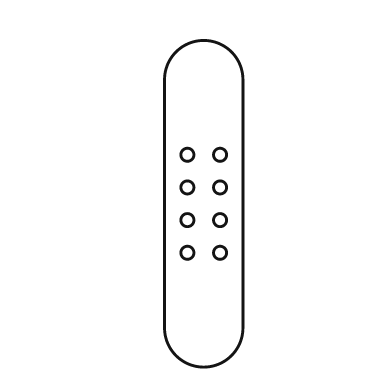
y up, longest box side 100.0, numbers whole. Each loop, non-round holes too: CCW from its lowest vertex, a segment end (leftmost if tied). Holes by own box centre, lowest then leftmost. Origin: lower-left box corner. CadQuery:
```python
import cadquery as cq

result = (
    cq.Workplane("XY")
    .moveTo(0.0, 12.0)
    .threePointArc((12.0, 0.0), (24.0, 12.0))
    .lineTo(24.0, 88.0)
    .threePointArc((12.0, 100.0), (0.0, 88.0))
    .close()
    .moveTo(7.0, 35.0)
    .circle(2.0)
    .moveTo(17.0, 35.0)
    .circle(2.0)
    .moveTo(7.0, 45.0)
    .circle(2.0)
    .moveTo(17.0, 45.0)
    .circle(2.0)
    .moveTo(7.0, 55.0)
    .circle(2.0)
    .moveTo(17.0, 55.0)
    .circle(2.0)
    .moveTo(7.0, 65.0)
    .circle(2.0)
    .moveTo(17.0, 65.0)
    .circle(2.0)
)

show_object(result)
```